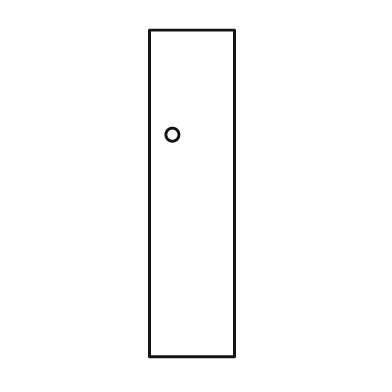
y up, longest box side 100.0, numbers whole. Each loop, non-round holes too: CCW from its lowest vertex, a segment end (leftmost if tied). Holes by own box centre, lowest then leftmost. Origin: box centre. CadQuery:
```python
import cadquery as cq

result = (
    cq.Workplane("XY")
    .moveTo(-13.0, -50.0)
    .lineTo(13.0, -50.0)
    .lineTo(13.0, 50.0)
    .lineTo(-13.0, 50.0)
    .close()
    .moveTo(-6.0, 18.0)
    .circle(2.0)
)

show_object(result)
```